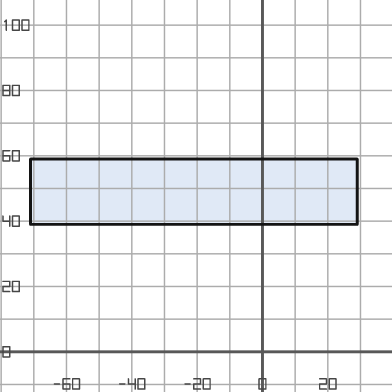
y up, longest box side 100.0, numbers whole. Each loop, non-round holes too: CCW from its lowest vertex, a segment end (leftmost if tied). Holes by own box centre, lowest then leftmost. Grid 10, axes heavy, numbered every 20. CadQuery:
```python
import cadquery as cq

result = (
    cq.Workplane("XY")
    .moveTo(-71.0, 39.0)
    .lineTo(29.0, 39.0)
    .lineTo(29.0, 59.0)
    .lineTo(-71.0, 59.0)
    .close()
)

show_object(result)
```